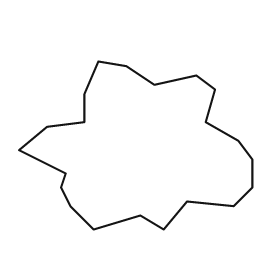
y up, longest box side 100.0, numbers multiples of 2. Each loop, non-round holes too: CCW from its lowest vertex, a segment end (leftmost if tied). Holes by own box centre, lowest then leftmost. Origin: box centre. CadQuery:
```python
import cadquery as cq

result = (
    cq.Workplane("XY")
    .moveTo(-18.0, -36.0)
    .lineTo(2.0, -30.0)
    .lineTo(12.0, -36.0)
    .lineTo(22.0, -24.0)
    .lineTo(42.0, -26.0)
    .lineTo(50.0, -18.0)
    .lineTo(50.0, -6.0)
    .lineTo(44.0, 2.0)
    .lineTo(30.0, 10.0)
    .lineTo(34.0, 24.0)
    .lineTo(26.0, 30.0)
    .lineTo(8.0, 26.0)
    .lineTo(-4.0, 34.0)
    .lineTo(-16.0, 36.0)
    .lineTo(-22.0, 22.0)
    .lineTo(-22.0, 10.0)
    .lineTo(-38.0, 8.0)
    .lineTo(-50.0, -2.0)
    .lineTo(-30.0, -12.0)
    .lineTo(-32.0, -18.0)
    .lineTo(-28.0, -26.0)
    .close()
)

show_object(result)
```